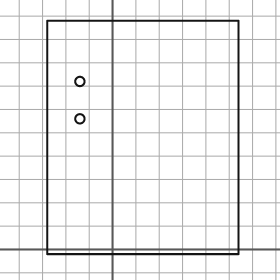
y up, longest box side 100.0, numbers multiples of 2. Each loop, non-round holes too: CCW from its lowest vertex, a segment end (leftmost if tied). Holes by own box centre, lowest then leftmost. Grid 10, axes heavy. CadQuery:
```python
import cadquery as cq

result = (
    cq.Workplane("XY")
    .moveTo(-28.0, -2.0)
    .lineTo(54.0, -2.0)
    .lineTo(54.0, 98.0)
    .lineTo(-28.0, 98.0)
    .close()
    .moveTo(-14.0, 56.0)
    .circle(2.0)
    .moveTo(-14.0, 72.0)
    .circle(2.0)
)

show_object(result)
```